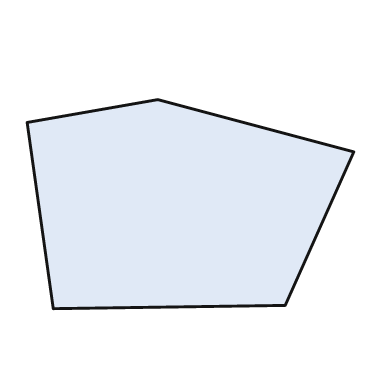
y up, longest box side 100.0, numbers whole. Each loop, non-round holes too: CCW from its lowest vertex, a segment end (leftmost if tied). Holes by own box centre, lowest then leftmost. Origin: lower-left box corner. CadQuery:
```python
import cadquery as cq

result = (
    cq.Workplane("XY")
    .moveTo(8.0, 0.0)
    .lineTo(79.0, 1.0)
    .lineTo(100.0, 48.0)
    .lineTo(40.0, 64.0)
    .lineTo(0.0, 57.0)
    .close()
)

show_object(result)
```